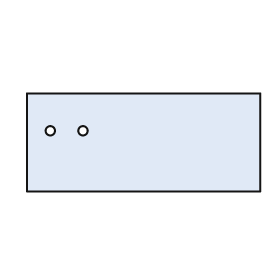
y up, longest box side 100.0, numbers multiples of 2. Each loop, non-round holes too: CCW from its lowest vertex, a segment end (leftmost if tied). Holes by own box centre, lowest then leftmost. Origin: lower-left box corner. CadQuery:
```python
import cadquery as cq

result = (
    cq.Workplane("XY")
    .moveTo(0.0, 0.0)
    .lineTo(100.0, 0.0)
    .lineTo(100.0, 42.0)
    .lineTo(0.0, 42.0)
    .close()
    .moveTo(10.0, 26.0)
    .circle(2.0)
    .moveTo(24.0, 26.0)
    .circle(2.0)
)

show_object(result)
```